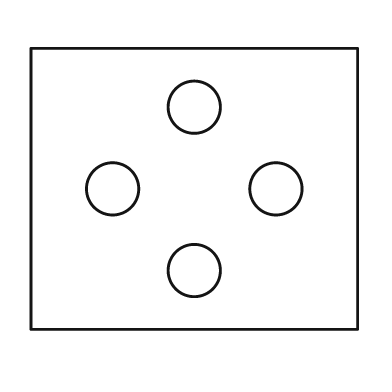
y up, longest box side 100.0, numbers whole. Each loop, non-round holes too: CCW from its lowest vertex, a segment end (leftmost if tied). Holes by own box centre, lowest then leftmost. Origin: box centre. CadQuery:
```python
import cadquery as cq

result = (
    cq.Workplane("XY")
    .moveTo(-50.0, -43.0)
    .lineTo(50.0, -43.0)
    .lineTo(50.0, 43.0)
    .lineTo(-50.0, 43.0)
    .close()
    .moveTo(0.0, -25.0)
    .circle(8.0)
    .moveTo(-25.0, 0.0)
    .circle(8.0)
    .moveTo(25.0, 0.0)
    .circle(8.0)
    .moveTo(0.0, 25.0)
    .circle(8.0)
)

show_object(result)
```